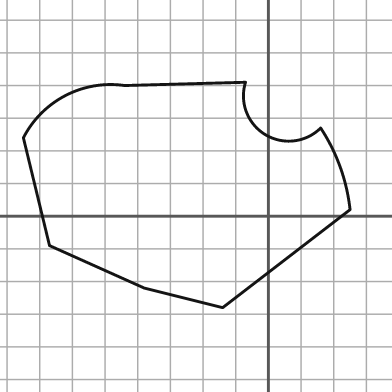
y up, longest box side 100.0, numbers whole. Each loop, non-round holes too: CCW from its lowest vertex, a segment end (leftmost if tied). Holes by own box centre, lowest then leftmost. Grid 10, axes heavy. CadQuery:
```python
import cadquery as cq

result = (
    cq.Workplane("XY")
    .moveTo(-14.0, -28.0)
    .lineTo(25.0, 2.0)
    .threePointArc((22.0, 15.0), (16.0, 27.0))
    .threePointArc((-1.0, 25.0), (-7.0, 41.0))
    .lineTo(-44.0, 40.0)
    .threePointArc((-62.0, 37.0), (-75.0, 24.0))
    .lineTo(-67.0, -9.0)
    .lineTo(-38.0, -22.0)
    .close()
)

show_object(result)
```